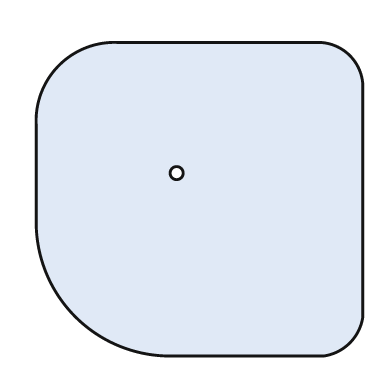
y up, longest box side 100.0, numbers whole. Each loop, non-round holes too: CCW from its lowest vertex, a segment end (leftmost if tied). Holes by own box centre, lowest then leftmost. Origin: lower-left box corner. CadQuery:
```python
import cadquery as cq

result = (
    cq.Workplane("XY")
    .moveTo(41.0, 0.0)
    .lineTo(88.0, 0.0)
    .threePointArc((96.0, 4.0), (100.0, 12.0))
    .lineTo(100.0, 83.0)
    .threePointArc((96.0, 92.0), (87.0, 96.0))
    .lineTo(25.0, 96.0)
    .threePointArc((7.0, 89.0), (0.0, 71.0))
    .lineTo(0.0, 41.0)
    .threePointArc((12.0, 12.0), (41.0, 0.0))
    .close()
    .moveTo(43.0, 56.0)
    .circle(2.0)
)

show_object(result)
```